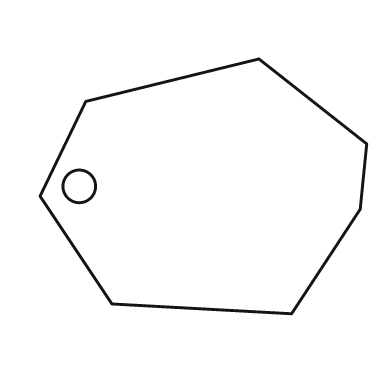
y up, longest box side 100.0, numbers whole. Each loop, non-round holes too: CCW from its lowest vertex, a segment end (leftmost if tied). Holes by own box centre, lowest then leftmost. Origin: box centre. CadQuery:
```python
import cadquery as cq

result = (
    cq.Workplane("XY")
    .moveTo(27.0, -39.0)
    .lineTo(48.0, -7.0)
    .lineTo(50.0, 13.0)
    .lineTo(17.0, 39.0)
    .lineTo(-36.0, 26.0)
    .lineTo(-50.0, -3.0)
    .lineTo(-28.0, -36.0)
    .close()
    .moveTo(-38.0, 0.0)
    .circle(5.0)
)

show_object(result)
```